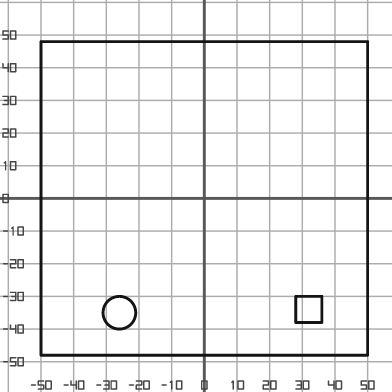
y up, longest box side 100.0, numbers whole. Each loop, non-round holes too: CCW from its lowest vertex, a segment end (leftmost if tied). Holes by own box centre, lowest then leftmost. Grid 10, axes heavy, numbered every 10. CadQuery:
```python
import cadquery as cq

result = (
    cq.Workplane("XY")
    .moveTo(-50.0, -48.0)
    .lineTo(50.0, -48.0)
    .lineTo(50.0, 48.0)
    .lineTo(-50.0, 48.0)
    .close()
    .moveTo(-26.0, -35.0)
    .circle(5.0)
    .moveTo(28.0, -38.0)
    .lineTo(36.0, -38.0)
    .lineTo(36.0, -30.0)
    .lineTo(28.0, -30.0)
    .close()
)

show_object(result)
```